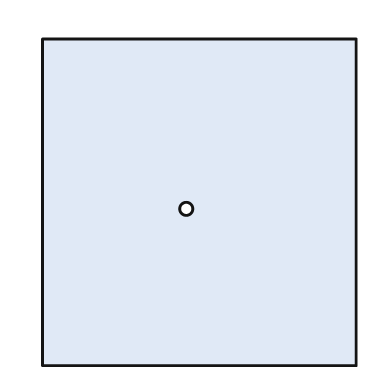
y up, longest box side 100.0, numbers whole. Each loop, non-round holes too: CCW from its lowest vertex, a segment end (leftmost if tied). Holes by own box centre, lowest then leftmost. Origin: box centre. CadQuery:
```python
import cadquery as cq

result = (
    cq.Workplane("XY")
    .moveTo(-48.0, -50.0)
    .lineTo(48.0, -50.0)
    .lineTo(48.0, 50.0)
    .lineTo(-48.0, 50.0)
    .close()
    .moveTo(-4.0, -2.0)
    .circle(2.0)
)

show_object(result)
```